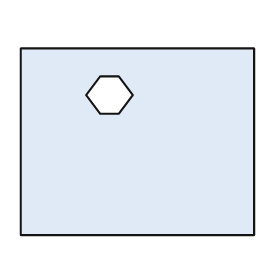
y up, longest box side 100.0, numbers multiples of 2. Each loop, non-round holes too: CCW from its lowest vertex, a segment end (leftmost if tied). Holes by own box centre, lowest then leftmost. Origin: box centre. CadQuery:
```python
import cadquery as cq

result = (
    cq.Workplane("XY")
    .moveTo(-50.0, -40.0)
    .lineTo(50.0, -40.0)
    .lineTo(50.0, 40.0)
    .lineTo(-50.0, 40.0)
    .close()
    .moveTo(-16.0, 12.0)
    .lineTo(-8.0, 12.0)
    .lineTo(-2.0, 20.0)
    .lineTo(-8.0, 28.0)
    .lineTo(-16.0, 28.0)
    .lineTo(-22.0, 20.0)
    .close()
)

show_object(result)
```